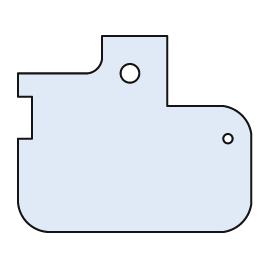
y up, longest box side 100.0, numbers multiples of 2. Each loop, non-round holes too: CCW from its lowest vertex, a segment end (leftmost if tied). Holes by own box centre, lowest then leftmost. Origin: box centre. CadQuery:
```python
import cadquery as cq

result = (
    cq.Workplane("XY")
    .moveTo(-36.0, -42.0)
    .lineTo(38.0, -42.0)
    .threePointArc((46.0, -38.0), (50.0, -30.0))
    .lineTo(50.0, 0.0)
    .threePointArc((46.0, 8.0), (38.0, 12.0))
    .lineTo(14.0, 12.0)
    .lineTo(14.0, 42.0)
    .lineTo(-14.0, 42.0)
    .lineTo(-14.0, 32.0)
    .threePointArc((-16.0, 28.0), (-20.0, 26.0))
    .lineTo(-50.0, 26.0)
    .lineTo(-50.0, 16.0)
    .lineTo(-44.0, 16.0)
    .lineTo(-44.0, -2.0)
    .lineTo(-50.0, -2.0)
    .lineTo(-50.0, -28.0)
    .threePointArc((-46.0, -38.0), (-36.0, -42.0))
    .close()
    .moveTo(40.0, -2.0)
    .circle(2.0)
    .moveTo(-2.0, 26.0)
    .circle(4.0)
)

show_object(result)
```